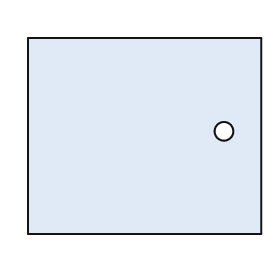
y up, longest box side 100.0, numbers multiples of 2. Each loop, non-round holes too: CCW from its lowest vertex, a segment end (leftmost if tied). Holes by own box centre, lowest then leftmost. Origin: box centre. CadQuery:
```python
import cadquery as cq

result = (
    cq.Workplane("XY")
    .moveTo(-50.0, -42.0)
    .lineTo(50.0, -42.0)
    .lineTo(50.0, 42.0)
    .lineTo(-50.0, 42.0)
    .close()
    .moveTo(34.0, 2.0)
    .circle(4.0)
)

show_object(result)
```